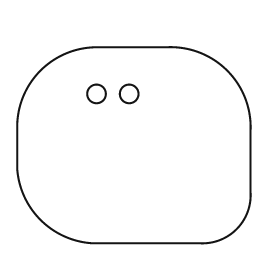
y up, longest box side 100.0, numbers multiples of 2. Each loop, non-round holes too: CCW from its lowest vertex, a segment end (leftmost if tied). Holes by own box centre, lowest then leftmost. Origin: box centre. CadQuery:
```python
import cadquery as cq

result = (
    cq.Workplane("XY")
    .moveTo(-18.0, -42.0)
    .lineTo(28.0, -42.0)
    .threePointArc((44.0, -36.0), (50.0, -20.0))
    .lineTo(50.0, 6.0)
    .threePointArc((40.0, 32.0), (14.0, 42.0))
    .lineTo(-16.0, 42.0)
    .threePointArc((-40.0, 32.0), (-50.0, 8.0))
    .lineTo(-50.0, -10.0)
    .threePointArc((-40.0, -32.0), (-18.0, -42.0))
    .close()
    .moveTo(-16.0, 22.0)
    .circle(4.0)
    .moveTo(-2.0, 22.0)
    .circle(4.0)
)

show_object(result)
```